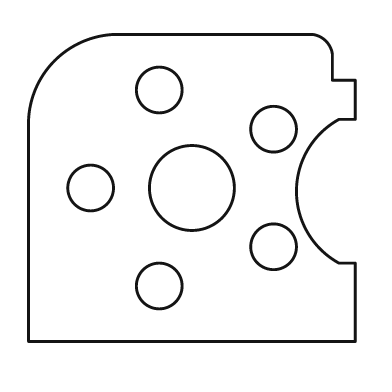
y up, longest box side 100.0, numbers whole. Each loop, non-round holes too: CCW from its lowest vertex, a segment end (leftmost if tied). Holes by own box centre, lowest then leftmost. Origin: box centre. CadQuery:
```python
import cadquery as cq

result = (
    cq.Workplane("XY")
    .moveTo(-50.0, -47.0)
    .lineTo(50.0, -47.0)
    .lineTo(50.0, -23.0)
    .lineTo(45.0, -23.0)
    .threePointArc((32.0, -1.0), (45.0, 21.0))
    .lineTo(50.0, 21.0)
    .lineTo(50.0, 33.0)
    .lineTo(43.0, 33.0)
    .lineTo(43.0, 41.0)
    .threePointArc((41.0, 45.0), (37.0, 47.0))
    .lineTo(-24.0, 47.0)
    .threePointArc((-42.0, 39.0), (-50.0, 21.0))
    .close()
    .moveTo(-10.0, -30.0)
    .circle(7.0)
    .moveTo(25.0, -18.0)
    .circle(7.0)
    .moveTo(-31.0, 0.0)
    .circle(7.0)
    .moveTo(0.0, 0.0)
    .circle(13.0)
    .moveTo(25.0, 18.0)
    .circle(7.0)
    .moveTo(-10.0, 30.0)
    .circle(7.0)
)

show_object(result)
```